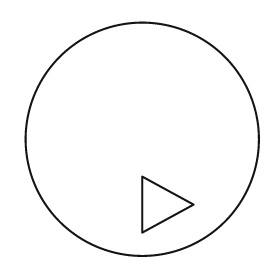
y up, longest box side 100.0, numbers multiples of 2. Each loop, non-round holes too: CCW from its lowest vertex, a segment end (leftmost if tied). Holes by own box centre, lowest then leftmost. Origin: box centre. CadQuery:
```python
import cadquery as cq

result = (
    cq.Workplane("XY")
    .moveTo(0.0, 0.0)
    .circle(50.0)
    .moveTo(0.0, -40.0)
    .lineTo(22.0, -28.0)
    .lineTo(0.0, -16.0)
    .close()
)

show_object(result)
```